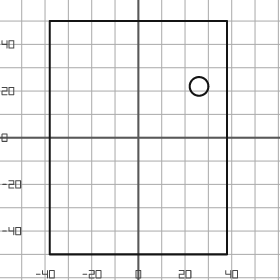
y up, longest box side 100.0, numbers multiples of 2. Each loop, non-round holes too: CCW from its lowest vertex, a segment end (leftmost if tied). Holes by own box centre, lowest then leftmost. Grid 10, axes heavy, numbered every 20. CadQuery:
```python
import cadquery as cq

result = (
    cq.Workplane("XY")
    .moveTo(-38.0, -50.0)
    .lineTo(38.0, -50.0)
    .lineTo(38.0, 50.0)
    .lineTo(-38.0, 50.0)
    .close()
    .moveTo(26.0, 22.0)
    .circle(4.0)
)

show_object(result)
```